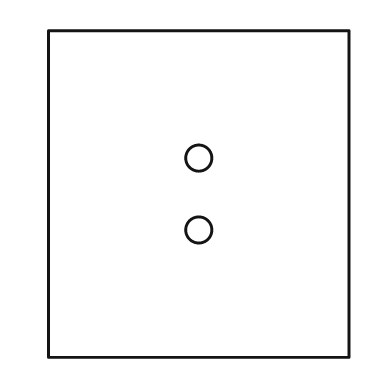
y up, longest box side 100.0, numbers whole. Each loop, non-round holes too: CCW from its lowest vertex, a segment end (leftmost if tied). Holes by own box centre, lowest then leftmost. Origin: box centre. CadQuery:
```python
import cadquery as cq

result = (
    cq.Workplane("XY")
    .moveTo(-46.0, -50.0)
    .lineTo(46.0, -50.0)
    .lineTo(46.0, 50.0)
    .lineTo(-46.0, 50.0)
    .close()
    .moveTo(0.0, -11.0)
    .circle(4.0)
    .moveTo(0.0, 11.0)
    .circle(4.0)
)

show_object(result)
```